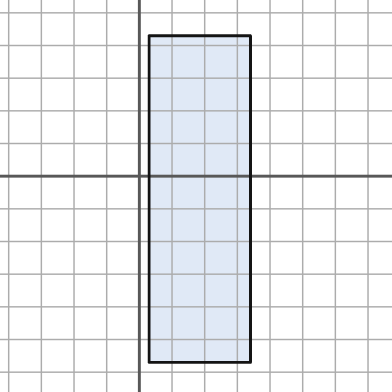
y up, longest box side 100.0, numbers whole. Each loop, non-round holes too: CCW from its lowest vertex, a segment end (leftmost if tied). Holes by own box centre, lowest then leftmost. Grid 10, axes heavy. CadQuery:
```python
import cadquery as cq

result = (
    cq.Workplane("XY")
    .moveTo(3.0, -57.0)
    .lineTo(34.0, -57.0)
    .lineTo(34.0, 43.0)
    .lineTo(3.0, 43.0)
    .close()
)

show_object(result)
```